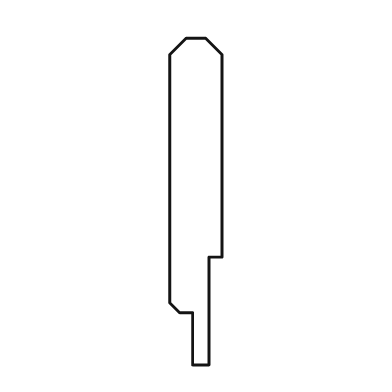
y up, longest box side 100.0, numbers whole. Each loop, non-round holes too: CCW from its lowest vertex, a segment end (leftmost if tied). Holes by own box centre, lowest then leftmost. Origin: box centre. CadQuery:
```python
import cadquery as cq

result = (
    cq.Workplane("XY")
    .moveTo(-1.0, -50.0)
    .lineTo(4.0, -50.0)
    .lineTo(4.0, -17.0)
    .lineTo(8.0, -17.0)
    .lineTo(8.0, 45.0)
    .lineTo(3.0, 50.0)
    .lineTo(-3.0, 50.0)
    .lineTo(-8.0, 45.0)
    .lineTo(-8.0, -31.0)
    .lineTo(-5.0, -34.0)
    .lineTo(-1.0, -34.0)
    .close()
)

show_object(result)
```